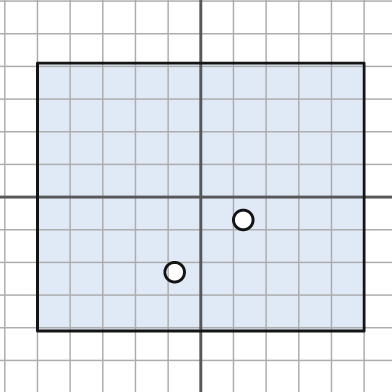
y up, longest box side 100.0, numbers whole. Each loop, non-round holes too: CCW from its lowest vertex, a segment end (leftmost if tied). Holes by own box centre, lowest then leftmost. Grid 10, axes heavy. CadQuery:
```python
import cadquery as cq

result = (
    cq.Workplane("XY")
    .moveTo(-50.0, -41.0)
    .lineTo(50.0, -41.0)
    .lineTo(50.0, 41.0)
    .lineTo(-50.0, 41.0)
    .close()
    .moveTo(-8.0, -23.0)
    .circle(3.0)
    .moveTo(13.0, -7.0)
    .circle(3.0)
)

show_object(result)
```